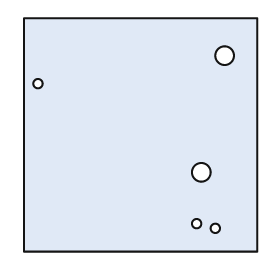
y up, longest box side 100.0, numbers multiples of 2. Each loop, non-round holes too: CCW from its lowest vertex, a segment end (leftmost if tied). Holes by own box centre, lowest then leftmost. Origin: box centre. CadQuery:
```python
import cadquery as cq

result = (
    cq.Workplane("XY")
    .moveTo(-50.0, -50.0)
    .lineTo(50.0, -50.0)
    .lineTo(50.0, 50.0)
    .lineTo(-50.0, 50.0)
    .close()
    .moveTo(32.0, -40.0)
    .circle(2.0)
    .moveTo(24.0, -38.0)
    .circle(2.0)
    .moveTo(26.0, -16.0)
    .circle(4.0)
    .moveTo(-44.0, 22.0)
    .circle(2.0)
    .moveTo(36.0, 34.0)
    .circle(4.0)
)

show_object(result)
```